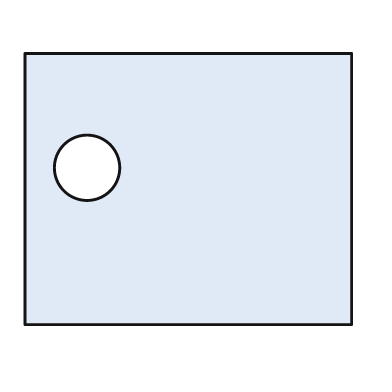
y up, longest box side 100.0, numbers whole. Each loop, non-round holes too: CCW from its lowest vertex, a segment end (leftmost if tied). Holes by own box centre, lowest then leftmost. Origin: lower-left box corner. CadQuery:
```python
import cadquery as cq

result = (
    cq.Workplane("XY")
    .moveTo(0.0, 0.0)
    .lineTo(100.0, 0.0)
    .lineTo(100.0, 83.0)
    .lineTo(0.0, 83.0)
    .close()
    .moveTo(19.0, 48.0)
    .circle(10.0)
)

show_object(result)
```